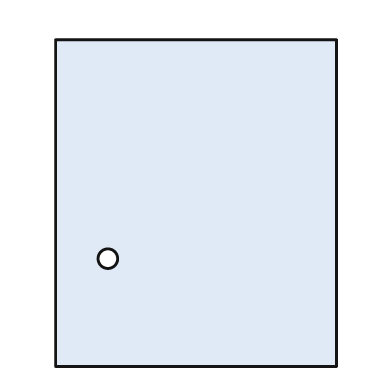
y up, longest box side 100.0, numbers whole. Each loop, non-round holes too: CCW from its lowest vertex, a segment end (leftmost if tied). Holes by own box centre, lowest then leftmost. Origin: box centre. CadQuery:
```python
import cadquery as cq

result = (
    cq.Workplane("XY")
    .moveTo(-43.0, -50.0)
    .lineTo(43.0, -50.0)
    .lineTo(43.0, 50.0)
    .lineTo(-43.0, 50.0)
    .close()
    .moveTo(-27.0, -17.0)
    .circle(3.0)
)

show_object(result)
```